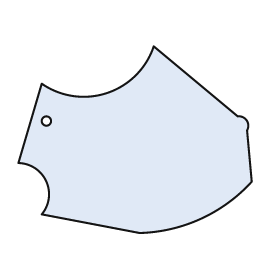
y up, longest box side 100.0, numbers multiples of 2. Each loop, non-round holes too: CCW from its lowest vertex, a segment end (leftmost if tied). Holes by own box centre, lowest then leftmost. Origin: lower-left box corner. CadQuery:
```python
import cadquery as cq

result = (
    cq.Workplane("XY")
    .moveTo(52.0, 0.0)
    .threePointArc((78.0, 6.0), (100.0, 22.0))
    .lineTo(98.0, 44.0)
    .threePointArc((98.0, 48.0), (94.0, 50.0))
    .lineTo(58.0, 80.0)
    .threePointArc((38.0, 60.0), (10.0, 64.0))
    .lineTo(0.0, 30.0)
    .threePointArc((12.0, 22.0), (10.0, 8.0))
    .close()
    .moveTo(12.0, 48.0)
    .circle(2.0)
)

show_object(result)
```